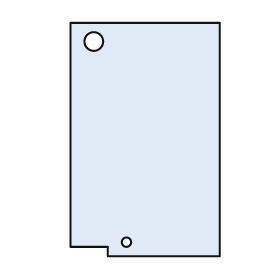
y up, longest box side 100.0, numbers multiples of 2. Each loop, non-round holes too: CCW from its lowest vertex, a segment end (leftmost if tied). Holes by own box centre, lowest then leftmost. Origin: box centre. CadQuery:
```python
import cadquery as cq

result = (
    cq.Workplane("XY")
    .moveTo(-16.0, -50.0)
    .lineTo(32.0, -50.0)
    .lineTo(32.0, 50.0)
    .lineTo(-32.0, 50.0)
    .lineTo(-32.0, -46.0)
    .lineTo(-16.0, -46.0)
    .close()
    .moveTo(-8.0, -44.0)
    .circle(2.0)
    .moveTo(-22.0, 42.0)
    .circle(4.0)
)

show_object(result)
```